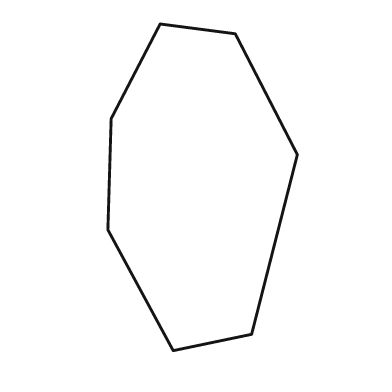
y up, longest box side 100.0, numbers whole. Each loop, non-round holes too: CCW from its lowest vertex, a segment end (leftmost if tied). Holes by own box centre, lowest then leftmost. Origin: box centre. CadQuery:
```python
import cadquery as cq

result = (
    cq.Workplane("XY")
    .moveTo(-9.0, -50.0)
    .lineTo(15.0, -45.0)
    .lineTo(29.0, 10.0)
    .lineTo(10.0, 47.0)
    .lineTo(-13.0, 50.0)
    .lineTo(-28.0, 21.0)
    .lineTo(-29.0, -13.0)
    .close()
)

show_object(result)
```